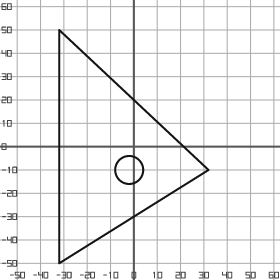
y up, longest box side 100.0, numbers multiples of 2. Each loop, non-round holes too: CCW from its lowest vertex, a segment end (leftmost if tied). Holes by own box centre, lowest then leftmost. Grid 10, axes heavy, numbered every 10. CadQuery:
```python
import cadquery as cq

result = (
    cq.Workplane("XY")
    .moveTo(-32.0, -50.0)
    .lineTo(32.0, -10.0)
    .lineTo(-32.0, 50.0)
    .close()
    .moveTo(-2.0, -10.0)
    .circle(6.0)
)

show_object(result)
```